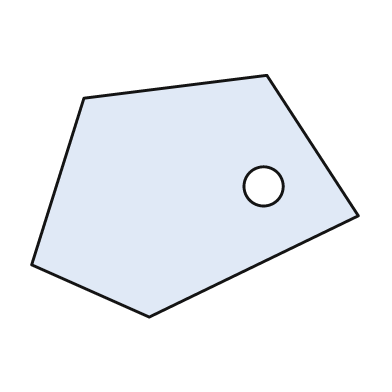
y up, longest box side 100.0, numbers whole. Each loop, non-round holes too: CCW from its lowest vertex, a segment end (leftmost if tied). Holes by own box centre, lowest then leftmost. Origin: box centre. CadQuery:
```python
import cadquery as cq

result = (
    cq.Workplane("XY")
    .moveTo(-14.0, -37.0)
    .lineTo(50.0, -6.0)
    .lineTo(22.0, 37.0)
    .lineTo(-34.0, 30.0)
    .lineTo(-50.0, -21.0)
    .close()
    .moveTo(21.0, 3.0)
    .circle(6.0)
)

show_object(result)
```